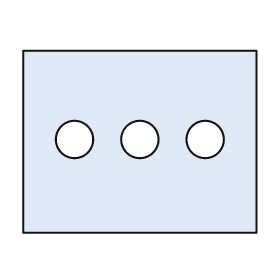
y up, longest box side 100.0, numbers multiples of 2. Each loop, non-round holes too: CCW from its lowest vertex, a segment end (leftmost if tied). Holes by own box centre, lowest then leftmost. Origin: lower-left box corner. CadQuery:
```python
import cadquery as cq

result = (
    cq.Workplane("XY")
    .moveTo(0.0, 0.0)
    .lineTo(100.0, 0.0)
    .lineTo(100.0, 78.0)
    .lineTo(0.0, 78.0)
    .close()
    .moveTo(22.0, 40.0)
    .circle(8.0)
    .moveTo(50.0, 40.0)
    .circle(8.0)
    .moveTo(78.0, 40.0)
    .circle(8.0)
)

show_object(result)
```